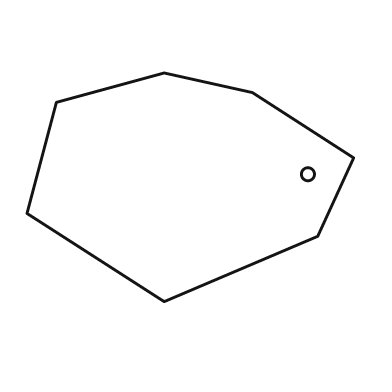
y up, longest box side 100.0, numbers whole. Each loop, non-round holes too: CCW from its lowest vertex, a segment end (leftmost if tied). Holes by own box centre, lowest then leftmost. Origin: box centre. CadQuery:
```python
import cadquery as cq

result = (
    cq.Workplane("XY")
    .moveTo(-8.0, -35.0)
    .lineTo(39.0, -15.0)
    .lineTo(50.0, 9.0)
    .lineTo(19.0, 29.0)
    .lineTo(-8.0, 35.0)
    .lineTo(-41.0, 26.0)
    .lineTo(-50.0, -8.0)
    .close()
    .moveTo(36.0, 4.0)
    .circle(2.0)
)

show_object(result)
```